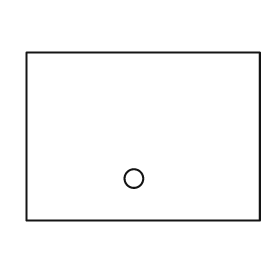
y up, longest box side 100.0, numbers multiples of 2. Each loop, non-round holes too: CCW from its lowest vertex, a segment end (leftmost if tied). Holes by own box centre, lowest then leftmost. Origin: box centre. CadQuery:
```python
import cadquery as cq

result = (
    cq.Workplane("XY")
    .moveTo(-50.0, -36.0)
    .lineTo(50.0, -36.0)
    .lineTo(50.0, 36.0)
    .lineTo(-50.0, 36.0)
    .close()
    .moveTo(-4.0, -18.0)
    .circle(4.0)
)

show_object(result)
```